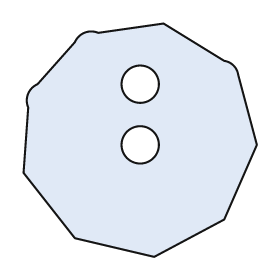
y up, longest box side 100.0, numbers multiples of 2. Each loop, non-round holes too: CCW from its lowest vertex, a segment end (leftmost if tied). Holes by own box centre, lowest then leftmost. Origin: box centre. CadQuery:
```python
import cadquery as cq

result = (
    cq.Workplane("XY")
    .moveTo(6.0, -50.0)
    .lineTo(36.0, -34.0)
    .lineTo(50.0, -2.0)
    .lineTo(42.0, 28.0)
    .threePointArc((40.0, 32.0), (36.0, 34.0))
    .lineTo(10.0, 50.0)
    .lineTo(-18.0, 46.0)
    .threePointArc((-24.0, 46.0), (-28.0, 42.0))
    .lineTo(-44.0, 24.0)
    .threePointArc((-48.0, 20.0), (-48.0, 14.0))
    .lineTo(-50.0, -14.0)
    .lineTo(-28.0, -42.0)
    .close()
    .moveTo(0.0, -2.0)
    .circle(8.0)
    .moveTo(0.0, 24.0)
    .circle(8.0)
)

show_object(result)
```